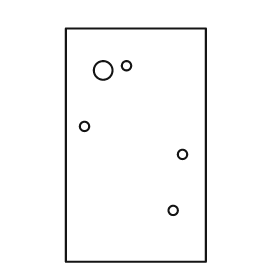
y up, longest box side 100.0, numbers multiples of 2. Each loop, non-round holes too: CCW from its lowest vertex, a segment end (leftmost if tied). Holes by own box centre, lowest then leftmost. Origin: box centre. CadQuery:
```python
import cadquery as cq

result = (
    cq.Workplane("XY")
    .moveTo(-30.0, -50.0)
    .lineTo(30.0, -50.0)
    .lineTo(30.0, 50.0)
    .lineTo(-30.0, 50.0)
    .close()
    .moveTo(16.0, -28.0)
    .circle(2.0)
    .moveTo(20.0, -4.0)
    .circle(2.0)
    .moveTo(-22.0, 8.0)
    .circle(2.0)
    .moveTo(-14.0, 32.0)
    .circle(4.0)
    .moveTo(-4.0, 34.0)
    .circle(2.0)
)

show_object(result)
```